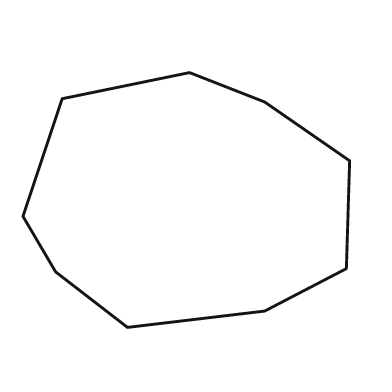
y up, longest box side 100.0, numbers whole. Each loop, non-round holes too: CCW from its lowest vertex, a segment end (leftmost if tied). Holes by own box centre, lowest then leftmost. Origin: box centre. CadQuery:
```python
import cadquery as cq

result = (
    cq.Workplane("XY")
    .moveTo(-18.0, -39.0)
    .lineTo(24.0, -34.0)
    .lineTo(49.0, -21.0)
    .lineTo(50.0, 12.0)
    .lineTo(24.0, 30.0)
    .lineTo(1.0, 39.0)
    .lineTo(-38.0, 31.0)
    .lineTo(-50.0, -5.0)
    .lineTo(-40.0, -22.0)
    .close()
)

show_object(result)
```